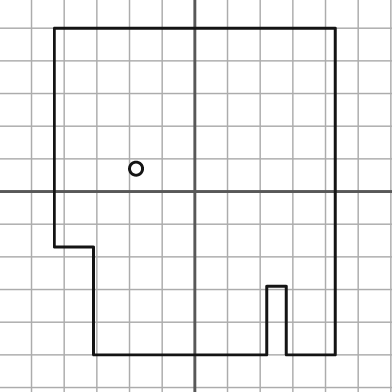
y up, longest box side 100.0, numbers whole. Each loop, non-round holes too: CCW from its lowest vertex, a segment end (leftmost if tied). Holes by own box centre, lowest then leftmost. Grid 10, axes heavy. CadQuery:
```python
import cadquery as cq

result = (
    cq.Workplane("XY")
    .moveTo(-31.0, -50.0)
    .lineTo(22.0, -50.0)
    .lineTo(22.0, -29.0)
    .lineTo(28.0, -29.0)
    .lineTo(28.0, -50.0)
    .lineTo(43.0, -50.0)
    .lineTo(43.0, 50.0)
    .lineTo(-43.0, 50.0)
    .lineTo(-43.0, -17.0)
    .lineTo(-31.0, -17.0)
    .close()
    .moveTo(-18.0, 7.0)
    .circle(2.0)
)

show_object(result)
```